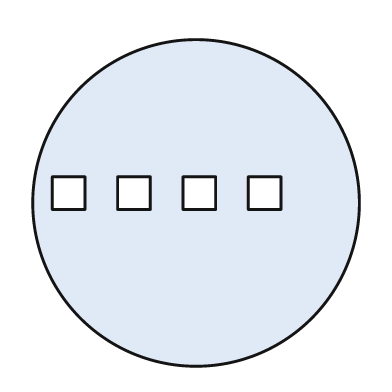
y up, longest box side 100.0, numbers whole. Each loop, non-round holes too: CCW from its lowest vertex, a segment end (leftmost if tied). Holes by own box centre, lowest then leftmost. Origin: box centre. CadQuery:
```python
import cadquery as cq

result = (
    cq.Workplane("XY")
    .moveTo(0.0, 0.0)
    .circle(50.0)
    .moveTo(-44.0, -2.0)
    .lineTo(-34.0, -2.0)
    .lineTo(-34.0, 8.0)
    .lineTo(-44.0, 8.0)
    .close()
    .moveTo(-24.0, -2.0)
    .lineTo(-14.0, -2.0)
    .lineTo(-14.0, 8.0)
    .lineTo(-24.0, 8.0)
    .close()
    .moveTo(-4.0, -2.0)
    .lineTo(6.0, -2.0)
    .lineTo(6.0, 8.0)
    .lineTo(-4.0, 8.0)
    .close()
    .moveTo(16.0, -2.0)
    .lineTo(26.0, -2.0)
    .lineTo(26.0, 8.0)
    .lineTo(16.0, 8.0)
    .close()
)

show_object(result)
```